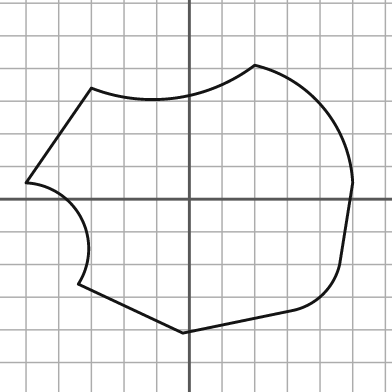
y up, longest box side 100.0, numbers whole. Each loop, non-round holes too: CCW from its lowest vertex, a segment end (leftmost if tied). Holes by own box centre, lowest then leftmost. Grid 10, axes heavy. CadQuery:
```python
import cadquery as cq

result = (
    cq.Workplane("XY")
    .moveTo(-2.0, -41.0)
    .lineTo(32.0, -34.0)
    .threePointArc((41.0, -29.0), (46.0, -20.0))
    .lineTo(50.0, 5.0)
    .threePointArc((41.0, 28.0), (20.0, 41.0))
    .threePointArc((-4.0, 31.0), (-30.0, 34.0))
    .lineTo(-50.0, 5.0)
    .threePointArc((-33.0, -6.0), (-34.0, -26.0))
    .close()
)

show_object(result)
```